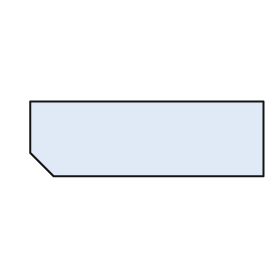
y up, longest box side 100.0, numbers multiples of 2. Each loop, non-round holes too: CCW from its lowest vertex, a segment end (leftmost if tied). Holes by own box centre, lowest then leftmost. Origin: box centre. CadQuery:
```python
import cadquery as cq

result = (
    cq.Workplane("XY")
    .moveTo(-40.0, -16.0)
    .lineTo(50.0, -16.0)
    .lineTo(50.0, 16.0)
    .lineTo(-50.0, 16.0)
    .lineTo(-50.0, -6.0)
    .close()
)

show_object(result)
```